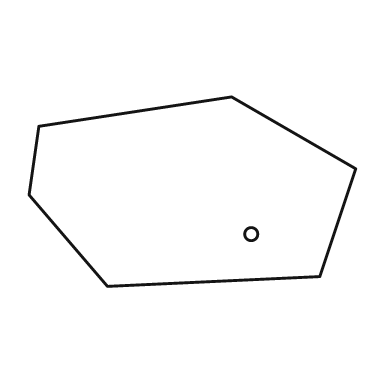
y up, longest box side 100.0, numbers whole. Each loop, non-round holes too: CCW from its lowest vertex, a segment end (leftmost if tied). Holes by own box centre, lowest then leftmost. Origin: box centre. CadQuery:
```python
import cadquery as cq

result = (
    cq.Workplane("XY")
    .moveTo(-26.0, -29.0)
    .lineTo(39.0, -26.0)
    .lineTo(50.0, 7.0)
    .lineTo(12.0, 29.0)
    .lineTo(-47.0, 20.0)
    .lineTo(-50.0, -1.0)
    .close()
    .moveTo(18.0, -13.0)
    .circle(2.0)
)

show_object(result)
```